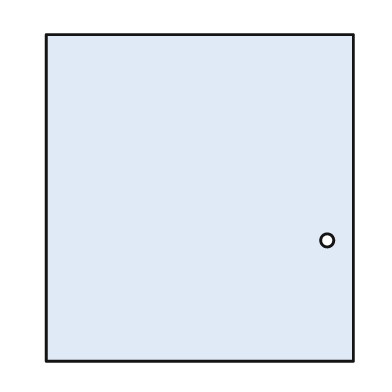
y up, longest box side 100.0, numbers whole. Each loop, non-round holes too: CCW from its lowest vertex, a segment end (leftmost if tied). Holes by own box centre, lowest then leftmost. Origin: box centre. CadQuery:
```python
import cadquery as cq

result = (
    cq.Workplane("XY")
    .moveTo(-47.0, -50.0)
    .lineTo(47.0, -50.0)
    .lineTo(47.0, 50.0)
    .lineTo(-47.0, 50.0)
    .close()
    .moveTo(39.0, -13.0)
    .circle(2.0)
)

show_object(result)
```